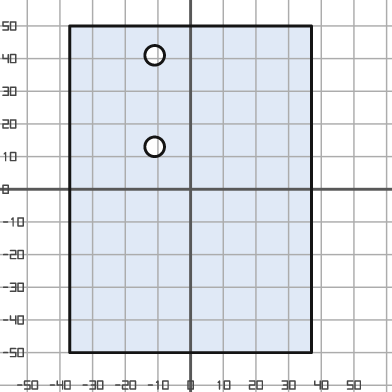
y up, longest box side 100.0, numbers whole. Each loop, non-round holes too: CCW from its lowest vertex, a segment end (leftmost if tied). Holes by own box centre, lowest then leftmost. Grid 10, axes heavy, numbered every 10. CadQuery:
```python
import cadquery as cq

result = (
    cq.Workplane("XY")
    .moveTo(-37.0, -50.0)
    .lineTo(37.0, -50.0)
    .lineTo(37.0, 50.0)
    .lineTo(-37.0, 50.0)
    .close()
    .moveTo(-11.0, 13.0)
    .circle(3.0)
    .moveTo(-11.0, 41.0)
    .circle(3.0)
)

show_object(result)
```